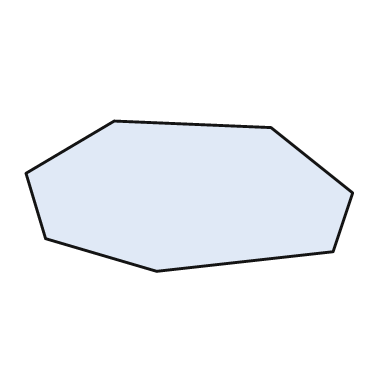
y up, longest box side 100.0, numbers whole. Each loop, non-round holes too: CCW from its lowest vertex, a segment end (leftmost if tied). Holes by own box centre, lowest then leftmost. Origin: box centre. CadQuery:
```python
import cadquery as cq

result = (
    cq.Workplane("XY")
    .moveTo(-10.0, -23.0)
    .lineTo(44.0, -17.0)
    .lineTo(50.0, 1.0)
    .lineTo(25.0, 21.0)
    .lineTo(-23.0, 23.0)
    .lineTo(-50.0, 7.0)
    .lineTo(-44.0, -13.0)
    .close()
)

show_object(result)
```